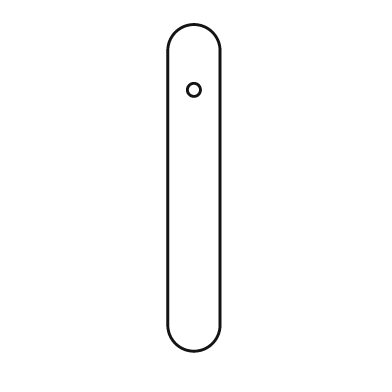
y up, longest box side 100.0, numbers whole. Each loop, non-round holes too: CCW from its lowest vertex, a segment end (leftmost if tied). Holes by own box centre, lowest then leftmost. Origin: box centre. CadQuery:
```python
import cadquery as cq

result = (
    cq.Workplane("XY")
    .moveTo(-8.0, -42.0)
    .threePointArc((0.0, -50.0), (8.0, -42.0))
    .lineTo(8.0, 42.0)
    .threePointArc((0.0, 50.0), (-8.0, 42.0))
    .close()
    .moveTo(0.0, 30.0)
    .circle(2.0)
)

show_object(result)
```